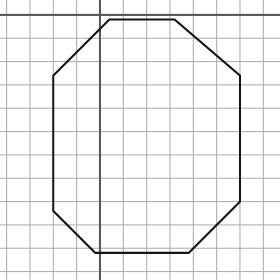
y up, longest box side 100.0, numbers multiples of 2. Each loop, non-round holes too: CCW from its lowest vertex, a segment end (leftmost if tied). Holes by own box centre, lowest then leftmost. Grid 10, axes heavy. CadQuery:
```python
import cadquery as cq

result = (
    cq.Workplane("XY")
    .moveTo(-2.0, -102.0)
    .lineTo(38.0, -102.0)
    .lineTo(60.0, -80.0)
    .lineTo(60.0, -26.0)
    .lineTo(32.0, -2.0)
    .lineTo(4.0, -2.0)
    .lineTo(-20.0, -26.0)
    .lineTo(-20.0, -84.0)
    .close()
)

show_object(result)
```